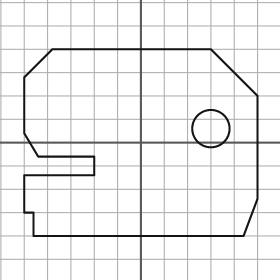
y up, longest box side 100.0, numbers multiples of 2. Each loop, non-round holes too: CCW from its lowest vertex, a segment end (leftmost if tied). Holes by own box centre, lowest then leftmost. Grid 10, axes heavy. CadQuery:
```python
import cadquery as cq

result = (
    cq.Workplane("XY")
    .moveTo(-46.0, -40.0)
    .lineTo(44.0, -40.0)
    .lineTo(50.0, -24.0)
    .lineTo(50.0, 20.0)
    .lineTo(30.0, 40.0)
    .lineTo(-38.0, 40.0)
    .lineTo(-50.0, 28.0)
    .lineTo(-50.0, 4.0)
    .lineTo(-44.0, -6.0)
    .lineTo(-20.0, -6.0)
    .lineTo(-20.0, -14.0)
    .lineTo(-50.0, -14.0)
    .lineTo(-50.0, -30.0)
    .lineTo(-46.0, -30.0)
    .close()
    .moveTo(30.0, 6.0)
    .circle(8.0)
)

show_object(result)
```